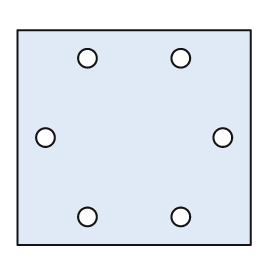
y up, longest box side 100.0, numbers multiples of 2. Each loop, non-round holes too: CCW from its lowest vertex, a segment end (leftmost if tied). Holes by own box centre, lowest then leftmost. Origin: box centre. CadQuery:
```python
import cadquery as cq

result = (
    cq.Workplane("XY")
    .moveTo(-50.0, -46.0)
    .lineTo(50.0, -46.0)
    .lineTo(50.0, 46.0)
    .lineTo(-50.0, 46.0)
    .close()
    .moveTo(-20.0, -34.0)
    .circle(4.0)
    .moveTo(20.0, -34.0)
    .circle(4.0)
    .moveTo(-38.0, 0.0)
    .circle(4.0)
    .moveTo(38.0, 0.0)
    .circle(4.0)
    .moveTo(-20.0, 34.0)
    .circle(4.0)
    .moveTo(20.0, 34.0)
    .circle(4.0)
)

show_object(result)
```